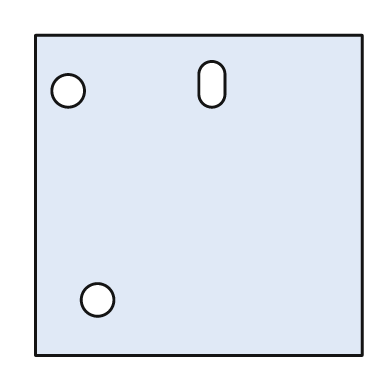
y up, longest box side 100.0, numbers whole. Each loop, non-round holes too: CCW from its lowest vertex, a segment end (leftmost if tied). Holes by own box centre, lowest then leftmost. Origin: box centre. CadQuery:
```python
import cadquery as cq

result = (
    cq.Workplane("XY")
    .moveTo(-50.0, -49.0)
    .lineTo(50.0, -49.0)
    .lineTo(50.0, 49.0)
    .lineTo(-50.0, 49.0)
    .close()
    .moveTo(-31.0, -32.0)
    .circle(5.0)
    .moveTo(-40.0, 32.0)
    .circle(5.0)
    .moveTo(0.0, 31.0)
    .threePointArc((4.0, 27.0), (8.0, 31.0))
    .lineTo(8.0, 37.0)
    .threePointArc((4.0, 41.0), (0.0, 37.0))
    .close()
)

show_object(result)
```